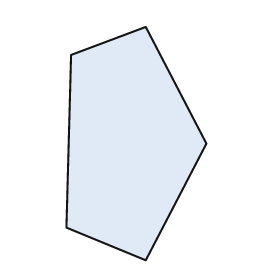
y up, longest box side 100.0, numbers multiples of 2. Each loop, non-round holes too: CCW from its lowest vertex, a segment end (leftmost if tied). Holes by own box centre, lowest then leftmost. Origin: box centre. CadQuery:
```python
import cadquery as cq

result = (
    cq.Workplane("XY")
    .moveTo(4.0, -50.0)
    .lineTo(30.0, 0.0)
    .lineTo(4.0, 50.0)
    .lineTo(-28.0, 38.0)
    .lineTo(-30.0, -36.0)
    .close()
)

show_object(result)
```